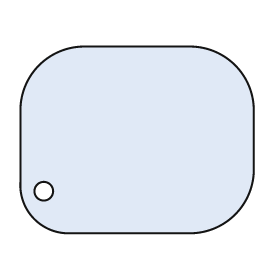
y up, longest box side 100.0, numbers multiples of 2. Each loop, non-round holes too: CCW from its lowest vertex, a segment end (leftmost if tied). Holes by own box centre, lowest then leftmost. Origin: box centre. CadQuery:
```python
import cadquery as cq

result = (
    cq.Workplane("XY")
    .moveTo(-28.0, -40.0)
    .lineTo(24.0, -40.0)
    .threePointArc((42.0, -32.0), (50.0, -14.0))
    .lineTo(50.0, 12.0)
    .threePointArc((42.0, 32.0), (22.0, 40.0))
    .lineTo(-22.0, 40.0)
    .threePointArc((-42.0, 32.0), (-50.0, 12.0))
    .lineTo(-50.0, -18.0)
    .threePointArc((-44.0, -34.0), (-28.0, -40.0))
    .close()
    .moveTo(-40.0, -22.0)
    .circle(4.0)
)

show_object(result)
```